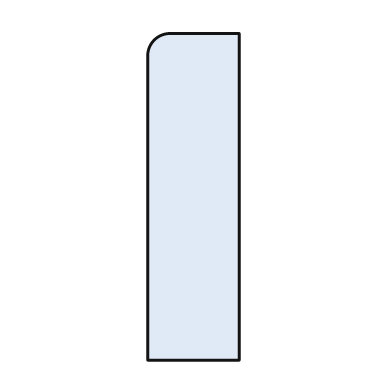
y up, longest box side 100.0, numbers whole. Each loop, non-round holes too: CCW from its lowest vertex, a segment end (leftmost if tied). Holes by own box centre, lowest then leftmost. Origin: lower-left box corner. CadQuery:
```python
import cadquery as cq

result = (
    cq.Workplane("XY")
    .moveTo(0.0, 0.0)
    .lineTo(28.0, 0.0)
    .lineTo(28.0, 100.0)
    .lineTo(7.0, 100.0)
    .threePointArc((2.0, 98.0), (0.0, 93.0))
    .close()
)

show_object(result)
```